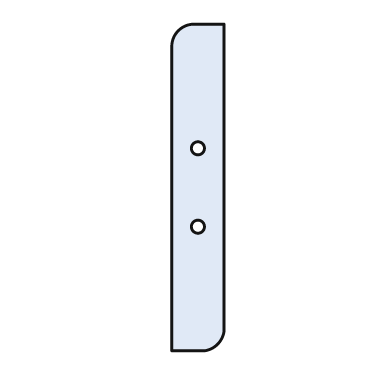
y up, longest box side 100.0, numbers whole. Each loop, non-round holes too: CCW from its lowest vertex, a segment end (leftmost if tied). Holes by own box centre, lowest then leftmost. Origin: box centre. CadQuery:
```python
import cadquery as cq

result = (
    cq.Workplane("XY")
    .moveTo(-8.0, -50.0)
    .lineTo(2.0, -50.0)
    .threePointArc((6.0, -48.0), (8.0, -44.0))
    .lineTo(8.0, 50.0)
    .lineTo(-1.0, 50.0)
    .threePointArc((-6.0, 48.0), (-8.0, 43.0))
    .close()
    .moveTo(0.0, -12.0)
    .circle(2.0)
    .moveTo(0.0, 12.0)
    .circle(2.0)
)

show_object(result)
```